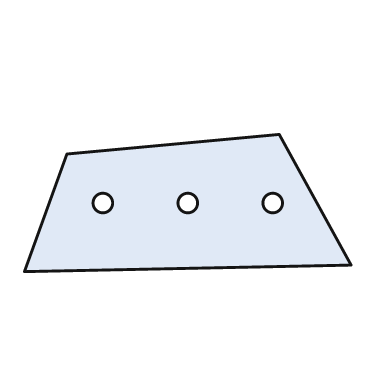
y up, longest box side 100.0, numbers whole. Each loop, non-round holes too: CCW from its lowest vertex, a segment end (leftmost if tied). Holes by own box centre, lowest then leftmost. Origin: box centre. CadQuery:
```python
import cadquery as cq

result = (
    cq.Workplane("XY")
    .moveTo(-50.0, -21.0)
    .lineTo(50.0, -19.0)
    .lineTo(28.0, 21.0)
    .lineTo(-37.0, 15.0)
    .close()
    .moveTo(-26.0, 0.0)
    .circle(3.0)
    .moveTo(0.0, 0.0)
    .circle(3.0)
    .moveTo(26.0, 0.0)
    .circle(3.0)
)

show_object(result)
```